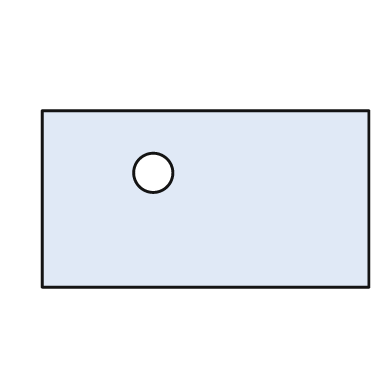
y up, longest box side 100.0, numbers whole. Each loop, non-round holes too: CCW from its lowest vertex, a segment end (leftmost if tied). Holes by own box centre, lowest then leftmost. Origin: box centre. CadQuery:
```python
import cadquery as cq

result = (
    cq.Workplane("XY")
    .moveTo(-50.0, -27.0)
    .lineTo(50.0, -27.0)
    .lineTo(50.0, 27.0)
    .lineTo(-50.0, 27.0)
    .close()
    .moveTo(-16.0, 8.0)
    .circle(6.0)
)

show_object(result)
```